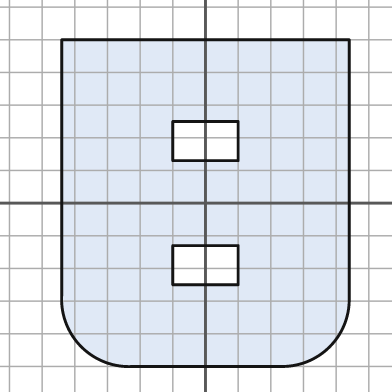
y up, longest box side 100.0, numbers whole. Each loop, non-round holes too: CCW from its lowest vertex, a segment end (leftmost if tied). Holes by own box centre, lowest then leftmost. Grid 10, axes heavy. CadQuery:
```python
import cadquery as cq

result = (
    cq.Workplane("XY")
    .moveTo(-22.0, -50.0)
    .lineTo(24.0, -50.0)
    .threePointArc((38.0, -44.0), (44.0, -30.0))
    .lineTo(44.0, 50.0)
    .lineTo(-44.0, 50.0)
    .lineTo(-44.0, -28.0)
    .threePointArc((-38.0, -44.0), (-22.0, -50.0))
    .close()
    .moveTo(-10.0, -25.0)
    .lineTo(10.0, -25.0)
    .lineTo(10.0, -13.0)
    .lineTo(-10.0, -13.0)
    .close()
    .moveTo(-10.0, 13.0)
    .lineTo(10.0, 13.0)
    .lineTo(10.0, 25.0)
    .lineTo(-10.0, 25.0)
    .close()
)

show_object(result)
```